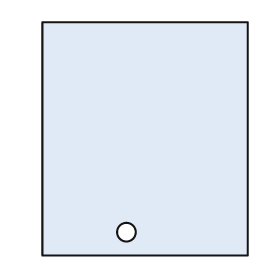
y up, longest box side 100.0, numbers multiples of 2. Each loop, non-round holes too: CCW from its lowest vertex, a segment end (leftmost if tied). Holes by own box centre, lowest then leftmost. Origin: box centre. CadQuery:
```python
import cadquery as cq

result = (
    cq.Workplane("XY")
    .moveTo(-44.0, -50.0)
    .lineTo(44.0, -50.0)
    .lineTo(44.0, 50.0)
    .lineTo(-44.0, 50.0)
    .close()
    .moveTo(-8.0, -40.0)
    .circle(4.0)
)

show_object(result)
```